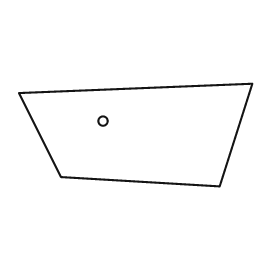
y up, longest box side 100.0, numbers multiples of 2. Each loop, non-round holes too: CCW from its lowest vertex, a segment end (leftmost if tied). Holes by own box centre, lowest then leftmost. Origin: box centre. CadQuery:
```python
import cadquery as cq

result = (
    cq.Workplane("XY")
    .moveTo(36.0, -22.0)
    .lineTo(50.0, 22.0)
    .lineTo(-50.0, 18.0)
    .lineTo(-32.0, -18.0)
    .close()
    .moveTo(-14.0, 6.0)
    .circle(2.0)
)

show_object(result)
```